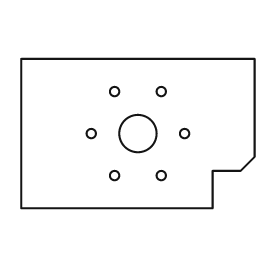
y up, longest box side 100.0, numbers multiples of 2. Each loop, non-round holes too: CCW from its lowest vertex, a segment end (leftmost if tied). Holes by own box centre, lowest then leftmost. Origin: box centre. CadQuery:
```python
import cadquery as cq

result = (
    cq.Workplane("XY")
    .moveTo(-50.0, -32.0)
    .lineTo(32.0, -32.0)
    .lineTo(32.0, -16.0)
    .lineTo(44.0, -16.0)
    .lineTo(50.0, -10.0)
    .lineTo(50.0, 32.0)
    .lineTo(-50.0, 32.0)
    .close()
    .moveTo(-10.0, -18.0)
    .circle(2.0)
    .moveTo(10.0, -18.0)
    .circle(2.0)
    .moveTo(-20.0, 0.0)
    .circle(2.0)
    .moveTo(0.0, 0.0)
    .circle(8.0)
    .moveTo(20.0, 0.0)
    .circle(2.0)
    .moveTo(-10.0, 18.0)
    .circle(2.0)
    .moveTo(10.0, 18.0)
    .circle(2.0)
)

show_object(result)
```